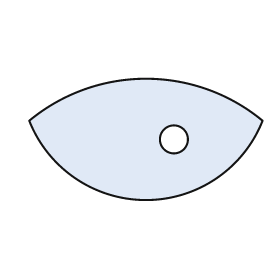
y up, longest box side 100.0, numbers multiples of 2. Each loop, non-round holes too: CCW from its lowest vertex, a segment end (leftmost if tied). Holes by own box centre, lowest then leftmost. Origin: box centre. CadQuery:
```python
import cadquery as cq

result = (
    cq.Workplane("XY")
    .moveTo(-50.0, 8.0)
    .threePointArc((0.0, -26.0), (50.0, 8.0))
    .threePointArc((0.0, 26.0), (-50.0, 8.0))
    .close()
    .moveTo(12.0, 0.0)
    .circle(6.0)
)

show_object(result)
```